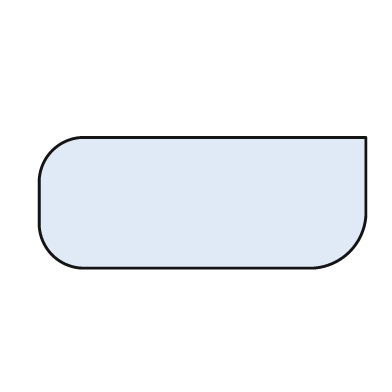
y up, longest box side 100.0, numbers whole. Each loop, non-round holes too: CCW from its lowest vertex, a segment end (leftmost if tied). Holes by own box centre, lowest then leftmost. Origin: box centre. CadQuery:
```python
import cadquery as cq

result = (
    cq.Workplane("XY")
    .moveTo(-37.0, -20.0)
    .lineTo(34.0, -20.0)
    .threePointArc((45.0, -15.0), (50.0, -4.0))
    .lineTo(50.0, 20.0)
    .lineTo(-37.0, 20.0)
    .threePointArc((-46.0, 16.0), (-50.0, 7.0))
    .lineTo(-50.0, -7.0)
    .threePointArc((-46.0, -16.0), (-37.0, -20.0))
    .close()
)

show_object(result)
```